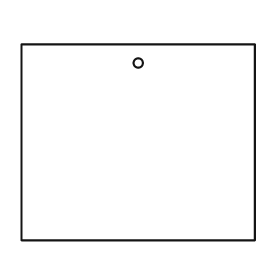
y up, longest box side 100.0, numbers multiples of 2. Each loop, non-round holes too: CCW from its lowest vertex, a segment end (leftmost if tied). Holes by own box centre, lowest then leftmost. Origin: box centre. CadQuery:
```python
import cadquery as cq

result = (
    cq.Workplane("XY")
    .moveTo(-50.0, -42.0)
    .lineTo(50.0, -42.0)
    .lineTo(50.0, 42.0)
    .lineTo(-50.0, 42.0)
    .close()
    .moveTo(0.0, 34.0)
    .circle(2.0)
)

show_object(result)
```